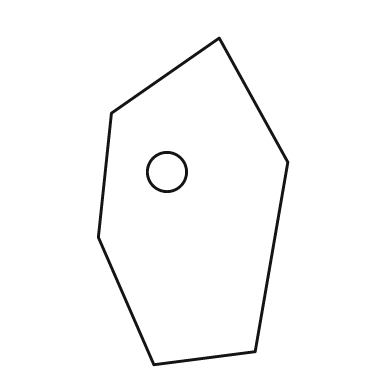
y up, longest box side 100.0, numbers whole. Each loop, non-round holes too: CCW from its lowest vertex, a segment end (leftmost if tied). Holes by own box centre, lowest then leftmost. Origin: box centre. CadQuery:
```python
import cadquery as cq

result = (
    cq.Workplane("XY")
    .moveTo(-12.0, -50.0)
    .lineTo(19.0, -46.0)
    .lineTo(29.0, 12.0)
    .lineTo(8.0, 50.0)
    .lineTo(-25.0, 27.0)
    .lineTo(-29.0, -11.0)
    .close()
    .moveTo(-8.0, 9.0)
    .circle(6.0)
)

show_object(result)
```